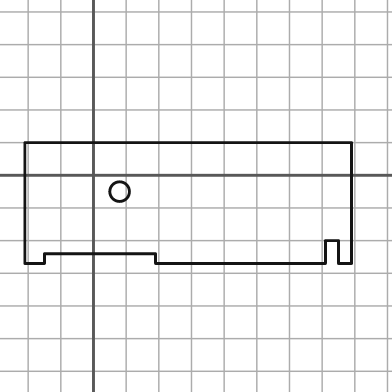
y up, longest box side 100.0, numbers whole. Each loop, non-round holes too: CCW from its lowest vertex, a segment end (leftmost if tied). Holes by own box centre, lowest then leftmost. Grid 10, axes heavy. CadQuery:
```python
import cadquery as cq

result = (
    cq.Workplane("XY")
    .moveTo(-21.0, -27.0)
    .lineTo(-15.0, -27.0)
    .lineTo(-15.0, -24.0)
    .lineTo(19.0, -24.0)
    .lineTo(19.0, -27.0)
    .lineTo(71.0, -27.0)
    .lineTo(71.0, -20.0)
    .lineTo(75.0, -20.0)
    .lineTo(75.0, -27.0)
    .lineTo(79.0, -27.0)
    .lineTo(79.0, 10.0)
    .lineTo(-21.0, 10.0)
    .close()
    .moveTo(8.0, -5.0)
    .circle(3.0)
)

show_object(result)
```